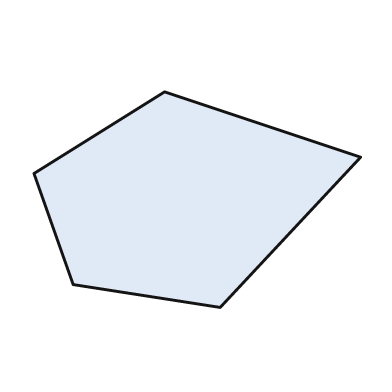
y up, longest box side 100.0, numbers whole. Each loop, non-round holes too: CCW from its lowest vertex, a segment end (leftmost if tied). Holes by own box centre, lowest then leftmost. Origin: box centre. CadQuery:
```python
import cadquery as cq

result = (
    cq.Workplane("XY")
    .moveTo(7.0, -33.0)
    .lineTo(50.0, 13.0)
    .lineTo(-10.0, 33.0)
    .lineTo(-50.0, 8.0)
    .lineTo(-38.0, -26.0)
    .close()
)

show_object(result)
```